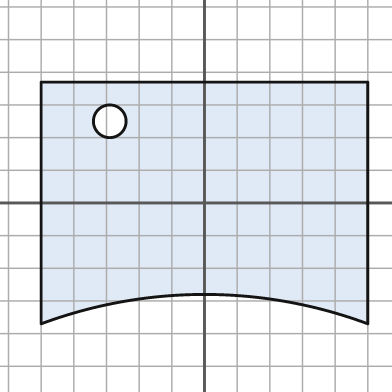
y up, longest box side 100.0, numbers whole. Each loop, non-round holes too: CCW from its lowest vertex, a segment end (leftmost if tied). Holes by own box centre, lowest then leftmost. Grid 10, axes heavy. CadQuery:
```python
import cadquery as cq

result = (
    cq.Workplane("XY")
    .moveTo(-50.0, -37.0)
    .threePointArc((0.0, -28.0), (50.0, -37.0))
    .lineTo(50.0, 37.0)
    .lineTo(-50.0, 37.0)
    .close()
    .moveTo(-29.0, 25.0)
    .circle(5.0)
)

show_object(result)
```